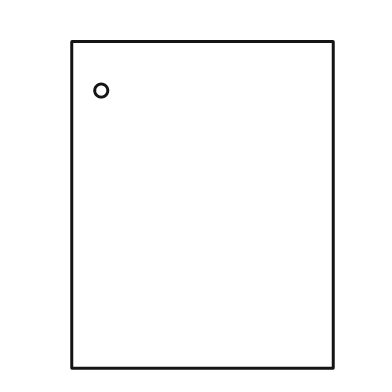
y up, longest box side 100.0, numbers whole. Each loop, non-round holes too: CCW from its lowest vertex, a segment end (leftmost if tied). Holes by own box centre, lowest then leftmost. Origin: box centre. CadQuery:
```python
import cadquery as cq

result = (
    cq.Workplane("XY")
    .moveTo(-40.0, -50.0)
    .lineTo(40.0, -50.0)
    .lineTo(40.0, 50.0)
    .lineTo(-40.0, 50.0)
    .close()
    .moveTo(-31.0, 35.0)
    .circle(2.0)
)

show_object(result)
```